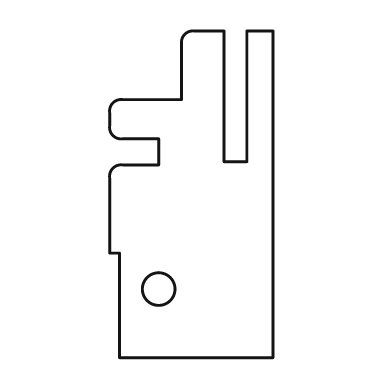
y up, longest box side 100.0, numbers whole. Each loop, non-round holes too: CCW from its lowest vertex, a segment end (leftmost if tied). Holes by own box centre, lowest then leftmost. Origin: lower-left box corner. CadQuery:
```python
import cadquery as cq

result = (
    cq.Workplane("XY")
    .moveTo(3.0, 0.0)
    .lineTo(50.0, 0.0)
    .lineTo(50.0, 100.0)
    .lineTo(42.0, 100.0)
    .lineTo(42.0, 60.0)
    .lineTo(35.0, 60.0)
    .lineTo(35.0, 100.0)
    .lineTo(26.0, 100.0)
    .threePointArc((23.0, 99.0), (22.0, 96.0))
    .lineTo(22.0, 79.0)
    .lineTo(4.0, 79.0)
    .threePointArc((1.0, 78.0), (0.0, 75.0))
    .lineTo(0.0, 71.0)
    .threePointArc((1.0, 68.0), (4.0, 67.0))
    .lineTo(15.0, 67.0)
    .lineTo(15.0, 59.0)
    .lineTo(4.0, 59.0)
    .threePointArc((1.0, 58.0), (0.0, 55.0))
    .lineTo(0.0, 32.0)
    .lineTo(3.0, 32.0)
    .close()
    .moveTo(15.0, 21.0)
    .circle(5.0)
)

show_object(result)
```